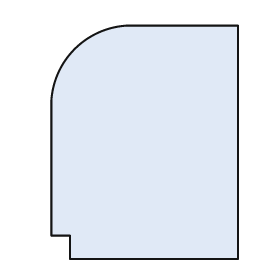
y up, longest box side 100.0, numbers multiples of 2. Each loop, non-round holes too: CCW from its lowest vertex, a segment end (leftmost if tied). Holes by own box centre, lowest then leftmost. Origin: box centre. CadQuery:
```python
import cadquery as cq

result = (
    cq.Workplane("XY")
    .moveTo(-32.0, -50.0)
    .lineTo(40.0, -50.0)
    .lineTo(40.0, 50.0)
    .lineTo(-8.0, 50.0)
    .threePointArc((-30.0, 40.0), (-40.0, 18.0))
    .lineTo(-40.0, -40.0)
    .lineTo(-32.0, -40.0)
    .close()
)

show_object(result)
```